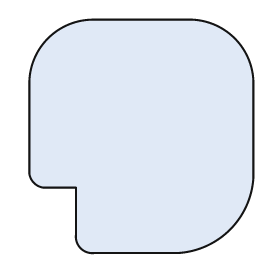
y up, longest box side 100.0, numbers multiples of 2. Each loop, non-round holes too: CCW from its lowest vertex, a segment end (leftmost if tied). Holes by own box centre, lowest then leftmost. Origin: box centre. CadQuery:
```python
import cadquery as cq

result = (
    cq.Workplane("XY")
    .moveTo(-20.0, -50.0)
    .lineTo(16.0, -50.0)
    .threePointArc((38.0, -40.0), (48.0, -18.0))
    .lineTo(48.0, 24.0)
    .threePointArc((40.0, 42.0), (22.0, 50.0))
    .lineTo(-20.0, 50.0)
    .threePointArc((-40.0, 42.0), (-48.0, 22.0))
    .lineTo(-48.0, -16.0)
    .threePointArc((-46.0, -20.0), (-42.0, -22.0))
    .lineTo(-28.0, -22.0)
    .lineTo(-28.0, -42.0)
    .threePointArc((-26.0, -48.0), (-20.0, -50.0))
    .close()
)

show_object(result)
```